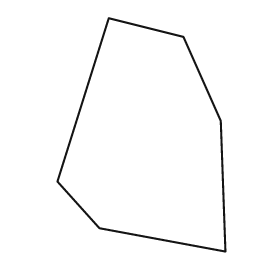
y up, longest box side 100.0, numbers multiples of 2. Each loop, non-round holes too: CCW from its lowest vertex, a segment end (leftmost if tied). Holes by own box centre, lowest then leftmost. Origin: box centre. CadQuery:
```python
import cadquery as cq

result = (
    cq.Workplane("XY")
    .moveTo(36.0, -50.0)
    .lineTo(34.0, 6.0)
    .lineTo(18.0, 42.0)
    .lineTo(-14.0, 50.0)
    .lineTo(-36.0, -20.0)
    .lineTo(-18.0, -40.0)
    .close()
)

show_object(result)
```